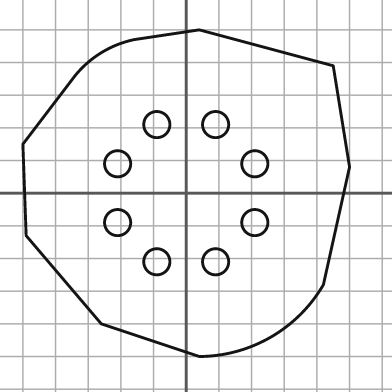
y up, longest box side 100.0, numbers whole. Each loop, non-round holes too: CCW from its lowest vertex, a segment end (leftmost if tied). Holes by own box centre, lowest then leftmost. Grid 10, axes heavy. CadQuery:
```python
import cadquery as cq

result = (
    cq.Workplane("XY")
    .moveTo(4.0, -50.0)
    .threePointArc((26.0, -44.0), (42.0, -28.0))
    .lineTo(50.0, 8.0)
    .lineTo(45.0, 39.0)
    .lineTo(4.0, 50.0)
    .lineTo(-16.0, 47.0)
    .threePointArc((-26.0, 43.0), (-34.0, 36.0))
    .lineTo(-50.0, 15.0)
    .lineTo(-49.0, -13.0)
    .lineTo(-26.0, -40.0)
    .close()
    .moveTo(-9.0, -21.0)
    .circle(4.0)
    .moveTo(9.0, -21.0)
    .circle(4.0)
    .moveTo(-21.0, -9.0)
    .circle(4.0)
    .moveTo(21.0, -9.0)
    .circle(4.0)
    .moveTo(-21.0, 9.0)
    .circle(4.0)
    .moveTo(21.0, 9.0)
    .circle(4.0)
    .moveTo(-9.0, 21.0)
    .circle(4.0)
    .moveTo(9.0, 21.0)
    .circle(4.0)
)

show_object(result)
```